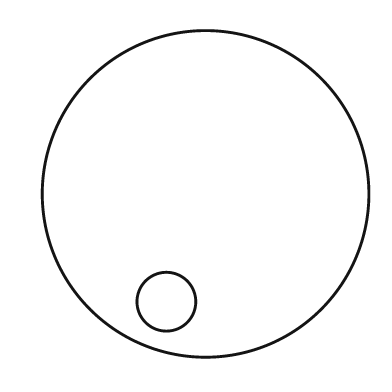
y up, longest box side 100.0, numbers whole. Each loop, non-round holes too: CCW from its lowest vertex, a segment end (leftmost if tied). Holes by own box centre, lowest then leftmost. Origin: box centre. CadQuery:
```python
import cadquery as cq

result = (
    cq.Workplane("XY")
    .moveTo(0.0, 0.0)
    .circle(50.0)
    .moveTo(-12.0, -33.0)
    .circle(9.0)
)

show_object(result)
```